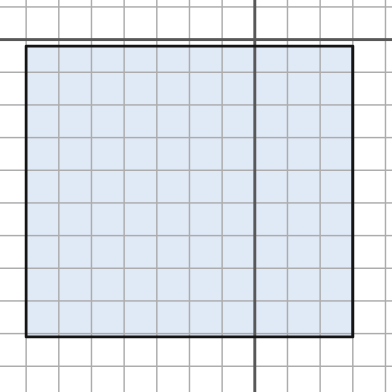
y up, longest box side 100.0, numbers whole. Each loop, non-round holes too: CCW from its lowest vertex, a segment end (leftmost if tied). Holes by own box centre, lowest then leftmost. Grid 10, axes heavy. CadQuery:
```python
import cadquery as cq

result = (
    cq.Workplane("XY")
    .moveTo(-70.0, -91.0)
    .lineTo(30.0, -91.0)
    .lineTo(30.0, -2.0)
    .lineTo(-70.0, -2.0)
    .close()
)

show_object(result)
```